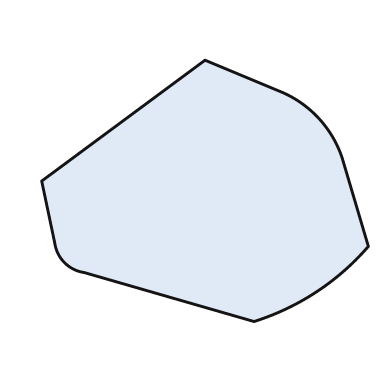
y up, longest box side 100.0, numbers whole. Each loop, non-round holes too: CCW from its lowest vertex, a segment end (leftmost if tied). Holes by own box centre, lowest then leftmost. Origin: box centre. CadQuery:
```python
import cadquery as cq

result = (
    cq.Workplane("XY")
    .moveTo(15.0, -40.0)
    .threePointArc((34.0, -31.0), (50.0, -17.0))
    .lineTo(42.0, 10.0)
    .threePointArc((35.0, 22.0), (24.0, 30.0))
    .lineTo(0.0, 40.0)
    .lineTo(-50.0, 3.0)
    .lineTo(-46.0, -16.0)
    .threePointArc((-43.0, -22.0), (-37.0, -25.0))
    .close()
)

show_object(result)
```